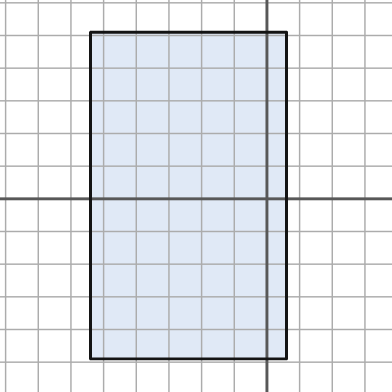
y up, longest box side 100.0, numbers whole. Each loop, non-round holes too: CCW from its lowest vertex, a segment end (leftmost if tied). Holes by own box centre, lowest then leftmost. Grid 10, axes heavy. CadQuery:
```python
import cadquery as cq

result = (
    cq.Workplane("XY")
    .moveTo(-54.0, -49.0)
    .lineTo(6.0, -49.0)
    .lineTo(6.0, 51.0)
    .lineTo(-54.0, 51.0)
    .close()
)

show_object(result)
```